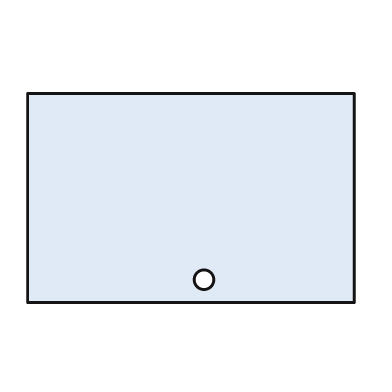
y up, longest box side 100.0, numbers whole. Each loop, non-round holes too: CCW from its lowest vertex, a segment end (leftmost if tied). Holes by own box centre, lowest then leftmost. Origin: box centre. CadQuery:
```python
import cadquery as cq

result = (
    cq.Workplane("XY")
    .moveTo(-50.0, -32.0)
    .lineTo(50.0, -32.0)
    .lineTo(50.0, 32.0)
    .lineTo(-50.0, 32.0)
    .close()
    .moveTo(4.0, -25.0)
    .circle(3.0)
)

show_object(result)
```